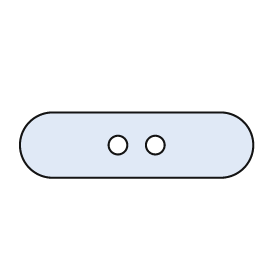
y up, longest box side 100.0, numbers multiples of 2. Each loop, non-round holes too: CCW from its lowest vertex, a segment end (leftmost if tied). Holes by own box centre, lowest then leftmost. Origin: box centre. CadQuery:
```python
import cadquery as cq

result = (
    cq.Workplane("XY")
    .moveTo(-36.0, -14.0)
    .lineTo(36.0, -14.0)
    .threePointArc((50.0, 0.0), (36.0, 14.0))
    .lineTo(-36.0, 14.0)
    .threePointArc((-50.0, 0.0), (-36.0, -14.0))
    .close()
    .moveTo(-8.0, 0.0)
    .circle(4.0)
    .moveTo(8.0, 0.0)
    .circle(4.0)
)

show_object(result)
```